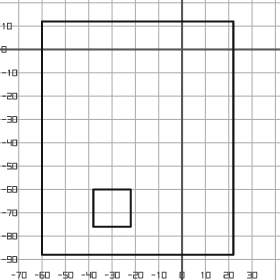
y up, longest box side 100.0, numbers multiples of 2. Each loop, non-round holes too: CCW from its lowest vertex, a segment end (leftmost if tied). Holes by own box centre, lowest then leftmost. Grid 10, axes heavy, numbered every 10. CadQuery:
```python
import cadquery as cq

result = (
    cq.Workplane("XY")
    .moveTo(-60.0, -88.0)
    .lineTo(22.0, -88.0)
    .lineTo(22.0, 12.0)
    .lineTo(-60.0, 12.0)
    .close()
    .moveTo(-38.0, -76.0)
    .lineTo(-22.0, -76.0)
    .lineTo(-22.0, -60.0)
    .lineTo(-38.0, -60.0)
    .close()
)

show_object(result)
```